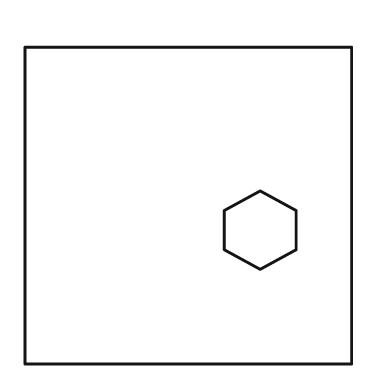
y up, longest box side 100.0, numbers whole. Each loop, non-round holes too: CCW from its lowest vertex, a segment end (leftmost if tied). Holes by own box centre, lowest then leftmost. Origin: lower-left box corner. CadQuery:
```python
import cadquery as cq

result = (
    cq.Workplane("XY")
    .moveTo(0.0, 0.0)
    .lineTo(100.0, 0.0)
    .lineTo(100.0, 97.0)
    .lineTo(0.0, 97.0)
    .close()
    .moveTo(72.0, 29.0)
    .lineTo(83.0, 35.0)
    .lineTo(83.0, 47.0)
    .lineTo(72.0, 53.0)
    .lineTo(61.0, 47.0)
    .lineTo(61.0, 35.0)
    .close()
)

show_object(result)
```